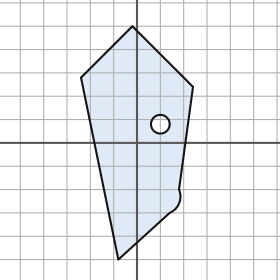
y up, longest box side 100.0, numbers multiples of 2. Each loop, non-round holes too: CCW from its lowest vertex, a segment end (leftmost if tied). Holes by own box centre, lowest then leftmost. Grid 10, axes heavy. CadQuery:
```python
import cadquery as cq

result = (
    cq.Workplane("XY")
    .moveTo(-8.0, -50.0)
    .lineTo(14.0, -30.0)
    .threePointArc((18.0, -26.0), (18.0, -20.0))
    .lineTo(24.0, 24.0)
    .lineTo(-2.0, 50.0)
    .lineTo(-24.0, 28.0)
    .close()
    .moveTo(10.0, 8.0)
    .circle(4.0)
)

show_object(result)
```